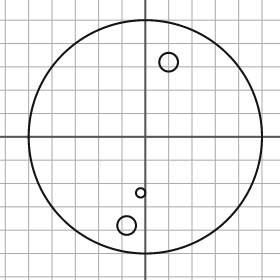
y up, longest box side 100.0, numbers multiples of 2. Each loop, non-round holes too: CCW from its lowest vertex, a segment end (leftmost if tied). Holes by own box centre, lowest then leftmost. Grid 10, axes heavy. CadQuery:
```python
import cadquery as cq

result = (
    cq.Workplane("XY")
    .moveTo(0.0, 0.0)
    .circle(50.0)
    .moveTo(-8.0, -38.0)
    .circle(4.0)
    .moveTo(-2.0, -24.0)
    .circle(2.0)
    .moveTo(10.0, 32.0)
    .circle(4.0)
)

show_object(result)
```